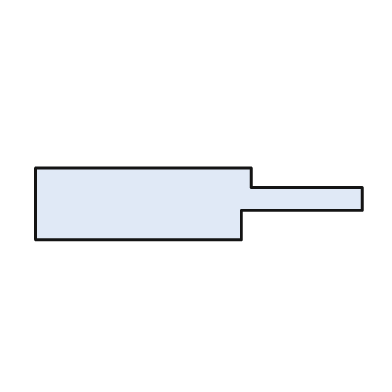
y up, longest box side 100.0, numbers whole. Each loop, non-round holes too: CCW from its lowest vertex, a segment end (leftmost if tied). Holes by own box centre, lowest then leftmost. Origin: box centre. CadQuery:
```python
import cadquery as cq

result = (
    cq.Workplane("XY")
    .moveTo(-50.0, -11.0)
    .lineTo(13.0, -11.0)
    .lineTo(13.0, -2.0)
    .lineTo(50.0, -2.0)
    .lineTo(50.0, 5.0)
    .lineTo(16.0, 5.0)
    .lineTo(16.0, 11.0)
    .lineTo(-50.0, 11.0)
    .close()
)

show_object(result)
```